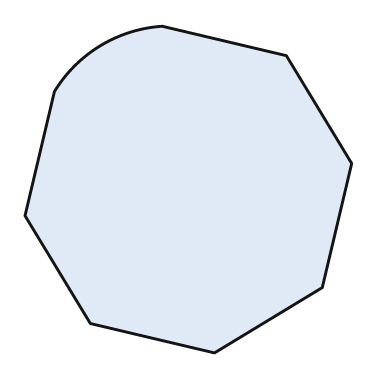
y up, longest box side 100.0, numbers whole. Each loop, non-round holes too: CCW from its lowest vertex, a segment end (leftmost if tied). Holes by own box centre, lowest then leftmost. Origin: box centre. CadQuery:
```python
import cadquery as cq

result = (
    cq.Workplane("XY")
    .moveTo(8.0, -50.0)
    .lineTo(41.0, -30.0)
    .lineTo(50.0, 8.0)
    .lineTo(30.0, 41.0)
    .lineTo(-8.0, 50.0)
    .threePointArc((-27.0, 44.0), (-41.0, 30.0))
    .lineTo(-50.0, -8.0)
    .lineTo(-30.0, -41.0)
    .close()
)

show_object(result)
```